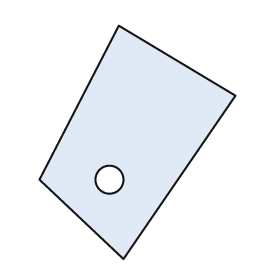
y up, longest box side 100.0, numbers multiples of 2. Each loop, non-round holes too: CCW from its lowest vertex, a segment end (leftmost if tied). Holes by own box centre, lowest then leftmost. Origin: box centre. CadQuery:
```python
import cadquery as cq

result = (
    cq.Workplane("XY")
    .moveTo(-6.0, -50.0)
    .lineTo(42.0, 20.0)
    .lineTo(-8.0, 50.0)
    .lineTo(-42.0, -16.0)
    .close()
    .moveTo(-12.0, -16.0)
    .circle(6.0)
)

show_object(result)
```